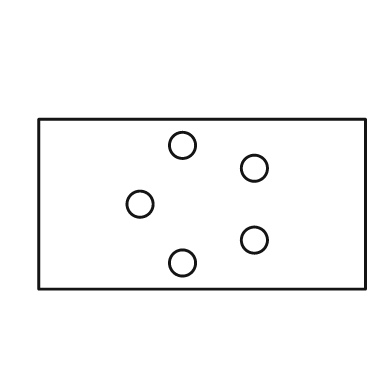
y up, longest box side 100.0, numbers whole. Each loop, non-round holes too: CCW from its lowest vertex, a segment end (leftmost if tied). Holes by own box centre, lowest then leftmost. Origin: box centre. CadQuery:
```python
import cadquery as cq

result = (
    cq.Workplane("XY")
    .moveTo(-50.0, -26.0)
    .lineTo(50.0, -26.0)
    .lineTo(50.0, 26.0)
    .lineTo(-50.0, 26.0)
    .close()
    .moveTo(-6.0, -18.0)
    .circle(4.0)
    .moveTo(16.0, -11.0)
    .circle(4.0)
    .moveTo(-19.0, 0.0)
    .circle(4.0)
    .moveTo(16.0, 11.0)
    .circle(4.0)
    .moveTo(-6.0, 18.0)
    .circle(4.0)
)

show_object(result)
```